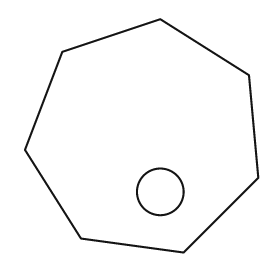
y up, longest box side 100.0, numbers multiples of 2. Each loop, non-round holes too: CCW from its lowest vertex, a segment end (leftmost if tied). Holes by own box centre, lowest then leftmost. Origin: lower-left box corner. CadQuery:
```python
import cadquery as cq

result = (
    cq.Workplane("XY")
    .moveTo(68.0, 0.0)
    .lineTo(100.0, 32.0)
    .lineTo(96.0, 76.0)
    .lineTo(58.0, 100.0)
    .lineTo(16.0, 86.0)
    .lineTo(0.0, 44.0)
    .lineTo(24.0, 6.0)
    .close()
    .moveTo(58.0, 26.0)
    .circle(10.0)
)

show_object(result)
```